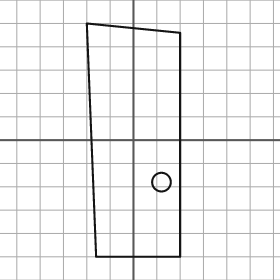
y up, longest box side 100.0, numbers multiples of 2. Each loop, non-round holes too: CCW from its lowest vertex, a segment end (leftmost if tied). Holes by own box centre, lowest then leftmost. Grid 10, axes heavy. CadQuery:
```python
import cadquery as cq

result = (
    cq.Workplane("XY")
    .moveTo(-16.0, -50.0)
    .lineTo(20.0, -50.0)
    .lineTo(20.0, 46.0)
    .lineTo(-20.0, 50.0)
    .close()
    .moveTo(12.0, -18.0)
    .circle(4.0)
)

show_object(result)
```